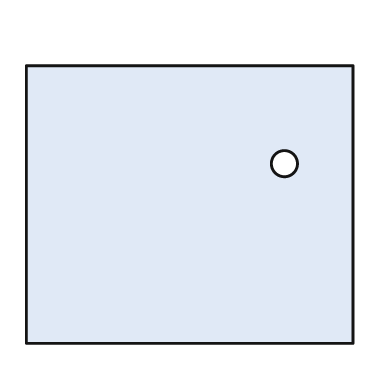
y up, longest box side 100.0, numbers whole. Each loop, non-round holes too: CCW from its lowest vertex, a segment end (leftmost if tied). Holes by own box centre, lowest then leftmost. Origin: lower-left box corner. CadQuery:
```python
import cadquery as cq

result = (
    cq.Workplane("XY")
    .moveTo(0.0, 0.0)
    .lineTo(100.0, 0.0)
    .lineTo(100.0, 85.0)
    .lineTo(0.0, 85.0)
    .close()
    .moveTo(79.0, 55.0)
    .circle(4.0)
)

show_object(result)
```